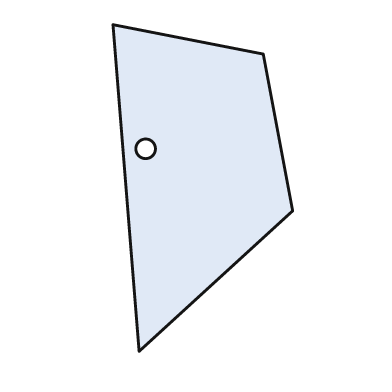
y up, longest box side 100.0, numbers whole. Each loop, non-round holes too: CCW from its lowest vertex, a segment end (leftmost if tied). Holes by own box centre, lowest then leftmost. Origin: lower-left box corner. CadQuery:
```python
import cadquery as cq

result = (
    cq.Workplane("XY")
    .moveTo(8.0, 0.0)
    .lineTo(55.0, 43.0)
    .lineTo(46.0, 91.0)
    .lineTo(0.0, 100.0)
    .close()
    .moveTo(10.0, 62.0)
    .circle(3.0)
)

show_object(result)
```